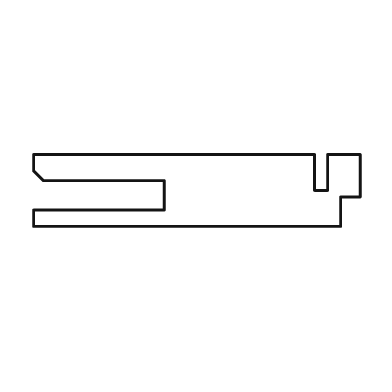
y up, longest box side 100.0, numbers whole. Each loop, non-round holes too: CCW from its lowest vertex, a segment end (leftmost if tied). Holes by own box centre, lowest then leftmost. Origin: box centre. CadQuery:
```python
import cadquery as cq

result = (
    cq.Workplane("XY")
    .moveTo(-50.0, -11.0)
    .lineTo(44.0, -11.0)
    .lineTo(44.0, -2.0)
    .lineTo(50.0, -2.0)
    .lineTo(50.0, 11.0)
    .lineTo(40.0, 11.0)
    .lineTo(40.0, 0.0)
    .lineTo(36.0, 0.0)
    .lineTo(36.0, 11.0)
    .lineTo(-50.0, 11.0)
    .lineTo(-50.0, 6.0)
    .lineTo(-47.0, 3.0)
    .lineTo(-10.0, 3.0)
    .lineTo(-10.0, -6.0)
    .lineTo(-50.0, -6.0)
    .close()
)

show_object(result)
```